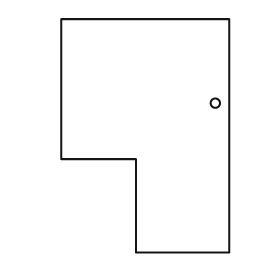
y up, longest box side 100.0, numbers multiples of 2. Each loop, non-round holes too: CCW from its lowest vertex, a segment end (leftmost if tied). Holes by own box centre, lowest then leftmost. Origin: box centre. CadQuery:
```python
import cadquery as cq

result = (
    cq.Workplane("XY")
    .moveTo(-4.0, -50.0)
    .lineTo(36.0, -50.0)
    .lineTo(36.0, 50.0)
    .lineTo(-36.0, 50.0)
    .lineTo(-36.0, -10.0)
    .lineTo(-4.0, -10.0)
    .close()
    .moveTo(30.0, 14.0)
    .circle(2.0)
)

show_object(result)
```